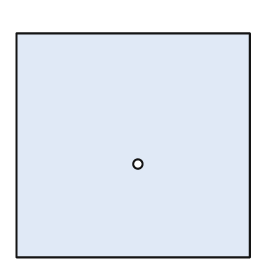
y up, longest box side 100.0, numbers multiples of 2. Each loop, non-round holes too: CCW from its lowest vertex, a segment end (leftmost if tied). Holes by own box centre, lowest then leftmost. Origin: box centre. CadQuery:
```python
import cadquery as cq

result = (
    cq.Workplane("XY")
    .moveTo(-50.0, -48.0)
    .lineTo(50.0, -48.0)
    .lineTo(50.0, 48.0)
    .lineTo(-50.0, 48.0)
    .close()
    .moveTo(2.0, -8.0)
    .circle(2.0)
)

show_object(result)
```